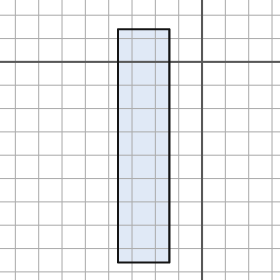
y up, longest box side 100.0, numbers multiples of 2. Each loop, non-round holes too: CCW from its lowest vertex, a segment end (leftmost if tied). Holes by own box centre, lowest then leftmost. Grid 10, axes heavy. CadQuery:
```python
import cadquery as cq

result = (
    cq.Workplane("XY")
    .moveTo(-36.0, -86.0)
    .lineTo(-14.0, -86.0)
    .lineTo(-14.0, 14.0)
    .lineTo(-36.0, 14.0)
    .close()
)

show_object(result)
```